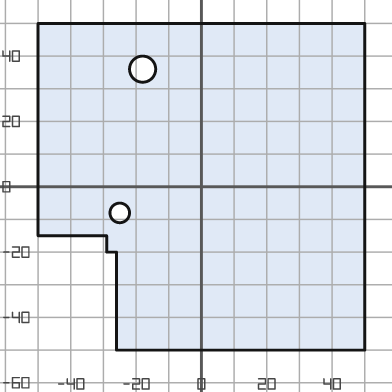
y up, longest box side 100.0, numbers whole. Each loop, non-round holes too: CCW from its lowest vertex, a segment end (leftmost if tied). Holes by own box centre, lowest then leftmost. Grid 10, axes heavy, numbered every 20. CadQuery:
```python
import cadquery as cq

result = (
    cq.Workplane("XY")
    .moveTo(-26.0, -50.0)
    .lineTo(50.0, -50.0)
    .lineTo(50.0, 50.0)
    .lineTo(-50.0, 50.0)
    .lineTo(-50.0, -15.0)
    .lineTo(-29.0, -15.0)
    .lineTo(-29.0, -20.0)
    .lineTo(-26.0, -20.0)
    .close()
    .moveTo(-25.0, -8.0)
    .circle(3.0)
    .moveTo(-18.0, 36.0)
    .circle(4.0)
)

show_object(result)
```